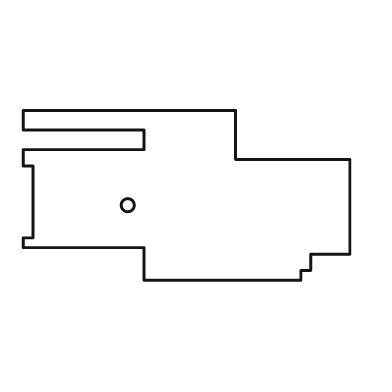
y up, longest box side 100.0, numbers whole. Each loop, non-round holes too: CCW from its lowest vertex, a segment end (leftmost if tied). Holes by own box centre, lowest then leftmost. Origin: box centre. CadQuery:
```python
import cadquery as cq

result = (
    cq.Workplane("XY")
    .moveTo(-13.0, -26.0)
    .lineTo(35.0, -26.0)
    .lineTo(35.0, -23.0)
    .lineTo(38.0, -23.0)
    .lineTo(38.0, -18.0)
    .lineTo(50.0, -18.0)
    .lineTo(50.0, 11.0)
    .lineTo(15.0, 11.0)
    .lineTo(15.0, 26.0)
    .lineTo(-50.0, 26.0)
    .lineTo(-50.0, 20.0)
    .lineTo(-13.0, 20.0)
    .lineTo(-13.0, 14.0)
    .lineTo(-50.0, 14.0)
    .lineTo(-50.0, 9.0)
    .lineTo(-47.0, 9.0)
    .lineTo(-47.0, -13.0)
    .lineTo(-50.0, -13.0)
    .lineTo(-50.0, -16.0)
    .lineTo(-13.0, -16.0)
    .close()
    .moveTo(-18.0, -3.0)
    .circle(2.0)
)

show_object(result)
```